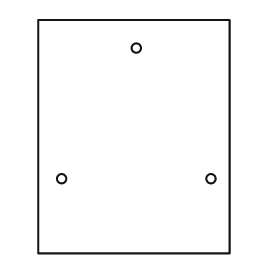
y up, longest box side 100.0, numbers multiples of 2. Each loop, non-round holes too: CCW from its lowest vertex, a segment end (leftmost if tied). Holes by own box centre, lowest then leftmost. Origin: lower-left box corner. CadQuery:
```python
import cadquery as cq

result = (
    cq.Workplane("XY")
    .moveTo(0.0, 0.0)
    .lineTo(82.0, 0.0)
    .lineTo(82.0, 100.0)
    .lineTo(0.0, 100.0)
    .close()
    .moveTo(10.0, 32.0)
    .circle(2.0)
    .moveTo(74.0, 32.0)
    .circle(2.0)
    .moveTo(42.0, 88.0)
    .circle(2.0)
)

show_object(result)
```